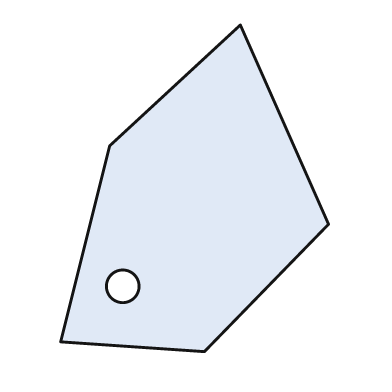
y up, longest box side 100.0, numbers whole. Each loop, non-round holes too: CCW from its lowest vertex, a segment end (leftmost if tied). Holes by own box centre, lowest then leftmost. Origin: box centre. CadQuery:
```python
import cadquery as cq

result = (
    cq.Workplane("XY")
    .moveTo(3.0, -50.0)
    .lineTo(41.0, -11.0)
    .lineTo(14.0, 50.0)
    .lineTo(-26.0, 13.0)
    .lineTo(-41.0, -47.0)
    .close()
    .moveTo(-22.0, -30.0)
    .circle(5.0)
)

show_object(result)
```